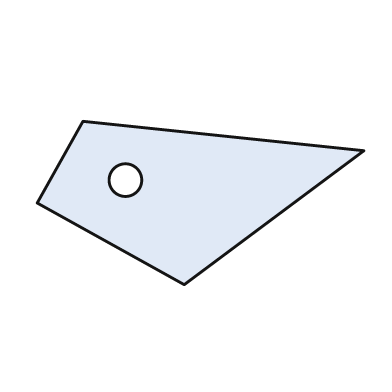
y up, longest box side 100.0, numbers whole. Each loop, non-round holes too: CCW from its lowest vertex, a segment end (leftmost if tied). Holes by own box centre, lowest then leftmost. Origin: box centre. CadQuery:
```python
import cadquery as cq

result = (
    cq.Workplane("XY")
    .moveTo(-5.0, -25.0)
    .lineTo(50.0, 16.0)
    .lineTo(-36.0, 25.0)
    .lineTo(-50.0, 0.0)
    .close()
    .moveTo(-23.0, 7.0)
    .circle(5.0)
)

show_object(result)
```